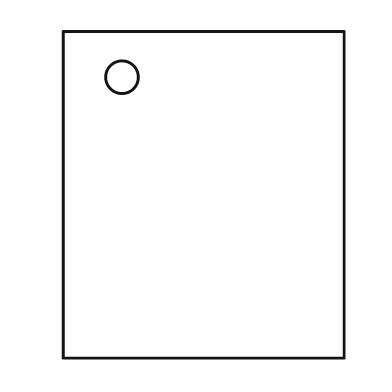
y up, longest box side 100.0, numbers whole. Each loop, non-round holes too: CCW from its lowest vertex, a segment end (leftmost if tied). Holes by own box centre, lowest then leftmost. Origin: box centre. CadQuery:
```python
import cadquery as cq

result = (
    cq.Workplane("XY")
    .moveTo(-43.0, -50.0)
    .lineTo(43.0, -50.0)
    .lineTo(43.0, 50.0)
    .lineTo(-43.0, 50.0)
    .close()
    .moveTo(-25.0, 36.0)
    .circle(5.0)
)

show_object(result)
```